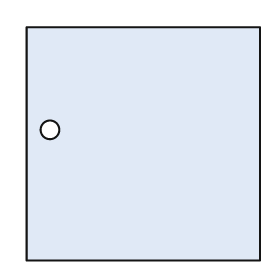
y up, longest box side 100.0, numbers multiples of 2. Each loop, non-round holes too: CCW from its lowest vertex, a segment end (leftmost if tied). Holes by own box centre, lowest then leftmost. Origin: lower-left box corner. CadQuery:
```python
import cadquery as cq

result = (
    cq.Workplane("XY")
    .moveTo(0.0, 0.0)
    .lineTo(100.0, 0.0)
    .lineTo(100.0, 100.0)
    .lineTo(0.0, 100.0)
    .close()
    .moveTo(10.0, 56.0)
    .circle(4.0)
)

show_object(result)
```